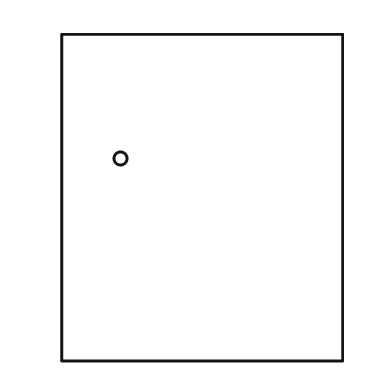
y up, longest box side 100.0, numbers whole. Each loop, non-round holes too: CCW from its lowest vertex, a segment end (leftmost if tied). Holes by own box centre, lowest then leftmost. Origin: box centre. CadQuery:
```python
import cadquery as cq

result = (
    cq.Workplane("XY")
    .moveTo(-43.0, -50.0)
    .lineTo(43.0, -50.0)
    .lineTo(43.0, 50.0)
    .lineTo(-43.0, 50.0)
    .close()
    .moveTo(-25.0, 12.0)
    .circle(2.0)
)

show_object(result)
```